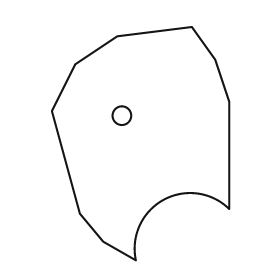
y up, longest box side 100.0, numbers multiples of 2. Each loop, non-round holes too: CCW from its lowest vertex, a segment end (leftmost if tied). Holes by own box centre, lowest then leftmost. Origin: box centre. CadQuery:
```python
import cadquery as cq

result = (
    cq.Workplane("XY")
    .moveTo(-2.0, -50.0)
    .threePointArc((10.0, -24.0), (38.0, -28.0))
    .lineTo(38.0, 18.0)
    .lineTo(32.0, 36.0)
    .lineTo(22.0, 50.0)
    .lineTo(-10.0, 46.0)
    .lineTo(-28.0, 34.0)
    .lineTo(-38.0, 14.0)
    .lineTo(-26.0, -30.0)
    .lineTo(-16.0, -42.0)
    .close()
    .moveTo(-8.0, 12.0)
    .circle(4.0)
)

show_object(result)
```